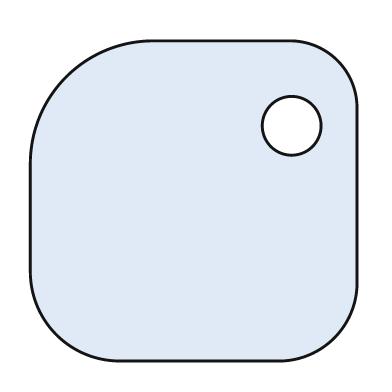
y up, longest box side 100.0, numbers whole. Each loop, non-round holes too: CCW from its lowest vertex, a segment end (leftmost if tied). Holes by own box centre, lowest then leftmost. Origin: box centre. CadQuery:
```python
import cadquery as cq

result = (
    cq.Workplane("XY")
    .moveTo(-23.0, -49.0)
    .lineTo(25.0, -49.0)
    .threePointArc((43.0, -42.0), (50.0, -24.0))
    .lineTo(50.0, 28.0)
    .threePointArc((44.0, 43.0), (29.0, 49.0))
    .lineTo(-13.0, 49.0)
    .threePointArc((-39.0, 38.0), (-50.0, 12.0))
    .lineTo(-50.0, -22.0)
    .threePointArc((-42.0, -41.0), (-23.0, -49.0))
    .close()
    .moveTo(30.0, 23.0)
    .circle(9.0)
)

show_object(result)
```